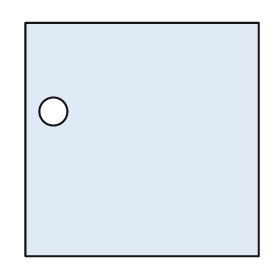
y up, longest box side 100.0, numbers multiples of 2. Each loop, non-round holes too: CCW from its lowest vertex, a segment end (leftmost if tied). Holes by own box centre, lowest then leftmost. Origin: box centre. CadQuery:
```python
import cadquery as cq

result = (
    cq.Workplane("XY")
    .moveTo(-50.0, -50.0)
    .lineTo(50.0, -50.0)
    .lineTo(50.0, 50.0)
    .lineTo(-50.0, 50.0)
    .close()
    .moveTo(-38.0, 12.0)
    .circle(6.0)
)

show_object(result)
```